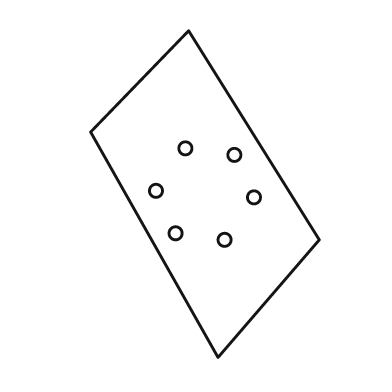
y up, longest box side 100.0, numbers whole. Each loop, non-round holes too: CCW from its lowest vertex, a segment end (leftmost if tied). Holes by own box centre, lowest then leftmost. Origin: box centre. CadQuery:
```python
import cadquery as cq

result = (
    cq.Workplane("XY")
    .moveTo(4.0, -50.0)
    .lineTo(35.0, -14.0)
    .lineTo(-5.0, 50.0)
    .lineTo(-35.0, 19.0)
    .close()
    .moveTo(6.0, -14.0)
    .circle(2.0)
    .moveTo(-9.0, -12.0)
    .circle(2.0)
    .moveTo(15.0, -1.0)
    .circle(2.0)
    .moveTo(-15.0, 1.0)
    .circle(2.0)
    .moveTo(9.0, 12.0)
    .circle(2.0)
    .moveTo(-6.0, 14.0)
    .circle(2.0)
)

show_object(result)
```